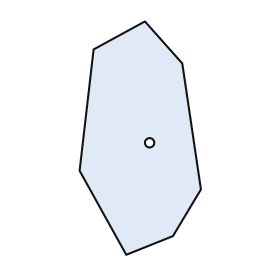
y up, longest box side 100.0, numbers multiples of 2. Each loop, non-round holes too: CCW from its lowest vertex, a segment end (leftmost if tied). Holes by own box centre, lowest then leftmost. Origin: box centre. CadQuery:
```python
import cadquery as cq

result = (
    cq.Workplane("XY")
    .moveTo(-6.0, -50.0)
    .lineTo(14.0, -42.0)
    .lineTo(26.0, -22.0)
    .lineTo(18.0, 32.0)
    .lineTo(2.0, 50.0)
    .lineTo(-20.0, 38.0)
    .lineTo(-26.0, -14.0)
    .close()
    .moveTo(4.0, -2.0)
    .circle(2.0)
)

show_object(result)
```